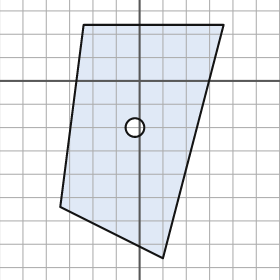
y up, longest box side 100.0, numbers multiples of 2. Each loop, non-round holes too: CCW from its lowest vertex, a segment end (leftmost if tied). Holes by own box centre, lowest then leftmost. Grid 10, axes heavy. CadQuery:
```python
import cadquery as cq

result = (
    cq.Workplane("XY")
    .moveTo(10.0, -76.0)
    .lineTo(36.0, 24.0)
    .lineTo(-24.0, 24.0)
    .lineTo(-34.0, -54.0)
    .close()
    .moveTo(-2.0, -20.0)
    .circle(4.0)
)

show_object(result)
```